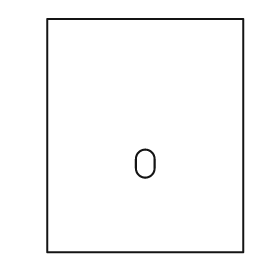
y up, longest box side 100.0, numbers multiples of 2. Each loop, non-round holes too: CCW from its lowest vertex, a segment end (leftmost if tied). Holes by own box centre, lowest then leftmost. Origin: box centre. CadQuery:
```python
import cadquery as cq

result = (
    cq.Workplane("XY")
    .moveTo(-42.0, -50.0)
    .lineTo(42.0, -50.0)
    .lineTo(42.0, 50.0)
    .lineTo(-42.0, 50.0)
    .close()
    .moveTo(-4.0, -14.0)
    .threePointArc((0.0, -18.0), (4.0, -14.0))
    .lineTo(4.0, -10.0)
    .threePointArc((0.0, -6.0), (-4.0, -10.0))
    .close()
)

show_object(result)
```